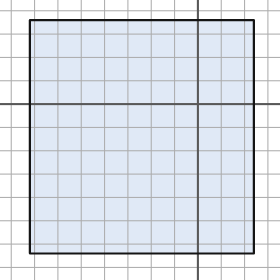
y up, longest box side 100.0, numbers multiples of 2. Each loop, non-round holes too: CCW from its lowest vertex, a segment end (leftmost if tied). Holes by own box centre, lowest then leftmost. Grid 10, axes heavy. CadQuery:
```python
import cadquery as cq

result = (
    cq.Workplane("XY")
    .moveTo(-72.0, -64.0)
    .lineTo(24.0, -64.0)
    .lineTo(24.0, 36.0)
    .lineTo(-72.0, 36.0)
    .close()
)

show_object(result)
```